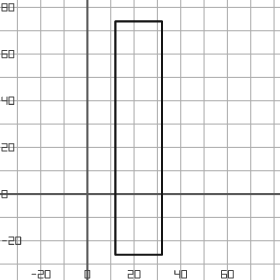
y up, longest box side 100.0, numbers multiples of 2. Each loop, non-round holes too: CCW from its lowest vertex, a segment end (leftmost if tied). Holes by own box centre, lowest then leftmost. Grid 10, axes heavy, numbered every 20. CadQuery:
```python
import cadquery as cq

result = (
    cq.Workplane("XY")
    .moveTo(12.0, -26.0)
    .lineTo(32.0, -26.0)
    .lineTo(32.0, 74.0)
    .lineTo(12.0, 74.0)
    .close()
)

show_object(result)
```